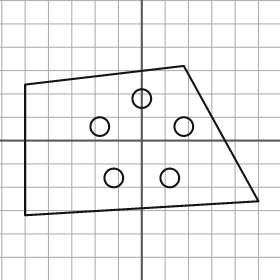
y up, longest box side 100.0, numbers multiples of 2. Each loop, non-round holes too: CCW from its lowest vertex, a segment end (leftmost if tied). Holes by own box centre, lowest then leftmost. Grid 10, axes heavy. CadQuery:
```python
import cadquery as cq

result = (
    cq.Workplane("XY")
    .moveTo(-50.0, -32.0)
    .lineTo(50.0, -26.0)
    .lineTo(18.0, 32.0)
    .lineTo(-50.0, 24.0)
    .close()
    .moveTo(-12.0, -16.0)
    .circle(4.0)
    .moveTo(12.0, -16.0)
    .circle(4.0)
    .moveTo(-18.0, 6.0)
    .circle(4.0)
    .moveTo(18.0, 6.0)
    .circle(4.0)
    .moveTo(0.0, 18.0)
    .circle(4.0)
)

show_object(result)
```